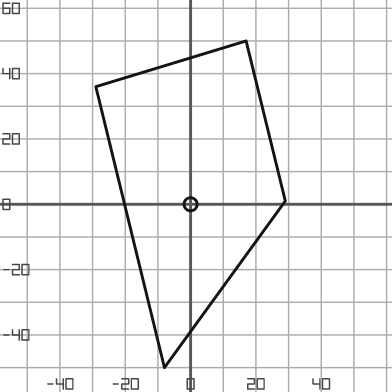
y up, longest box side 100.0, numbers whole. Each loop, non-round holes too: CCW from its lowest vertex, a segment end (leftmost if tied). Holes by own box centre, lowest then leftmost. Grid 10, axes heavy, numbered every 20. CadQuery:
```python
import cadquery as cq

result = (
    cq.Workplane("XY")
    .moveTo(-8.0, -50.0)
    .lineTo(29.0, 1.0)
    .lineTo(17.0, 50.0)
    .lineTo(-29.0, 36.0)
    .close()
    .moveTo(0.0, 0.0)
    .circle(2.0)
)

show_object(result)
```